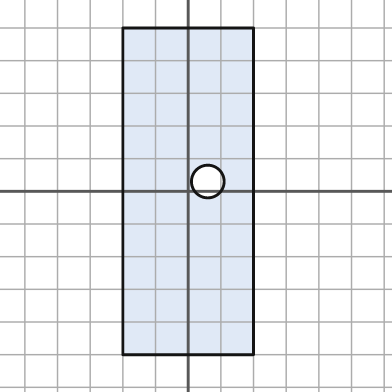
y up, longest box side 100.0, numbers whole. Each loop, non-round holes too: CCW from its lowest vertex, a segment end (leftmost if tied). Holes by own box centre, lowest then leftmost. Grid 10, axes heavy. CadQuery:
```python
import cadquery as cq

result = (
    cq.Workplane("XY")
    .moveTo(-20.0, -50.0)
    .lineTo(20.0, -50.0)
    .lineTo(20.0, 50.0)
    .lineTo(-20.0, 50.0)
    .close()
    .moveTo(6.0, 3.0)
    .circle(5.0)
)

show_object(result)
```